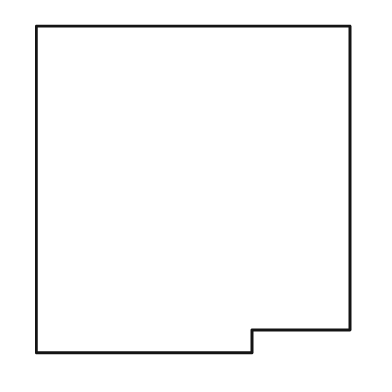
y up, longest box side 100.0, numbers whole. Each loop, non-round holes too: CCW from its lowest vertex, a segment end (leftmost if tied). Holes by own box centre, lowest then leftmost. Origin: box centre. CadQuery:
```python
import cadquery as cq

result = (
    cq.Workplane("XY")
    .moveTo(-48.0, -50.0)
    .lineTo(18.0, -50.0)
    .lineTo(18.0, -43.0)
    .lineTo(48.0, -43.0)
    .lineTo(48.0, 50.0)
    .lineTo(-48.0, 50.0)
    .close()
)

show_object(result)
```